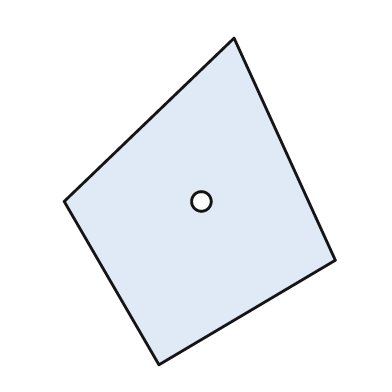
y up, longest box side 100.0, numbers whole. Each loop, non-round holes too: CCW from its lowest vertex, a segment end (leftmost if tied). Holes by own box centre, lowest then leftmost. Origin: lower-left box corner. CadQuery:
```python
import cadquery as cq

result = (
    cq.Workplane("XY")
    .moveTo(29.0, 0.0)
    .lineTo(83.0, 32.0)
    .lineTo(52.0, 100.0)
    .lineTo(0.0, 50.0)
    .close()
    .moveTo(42.0, 50.0)
    .circle(3.0)
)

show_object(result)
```